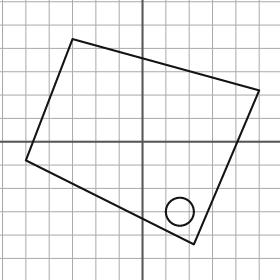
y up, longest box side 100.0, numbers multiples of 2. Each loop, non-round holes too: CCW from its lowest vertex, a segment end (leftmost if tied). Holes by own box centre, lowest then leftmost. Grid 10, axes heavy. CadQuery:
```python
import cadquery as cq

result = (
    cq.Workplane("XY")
    .moveTo(22.0, -44.0)
    .lineTo(50.0, 22.0)
    .lineTo(-30.0, 44.0)
    .lineTo(-50.0, -8.0)
    .close()
    .moveTo(16.0, -30.0)
    .circle(6.0)
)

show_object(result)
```